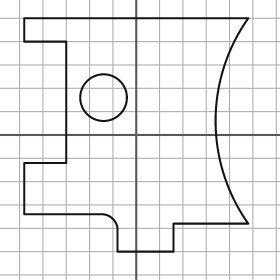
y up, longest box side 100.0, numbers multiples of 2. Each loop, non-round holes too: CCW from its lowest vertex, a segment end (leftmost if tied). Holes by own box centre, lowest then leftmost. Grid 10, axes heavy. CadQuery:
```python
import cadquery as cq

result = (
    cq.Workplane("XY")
    .moveTo(-8.0, -50.0)
    .lineTo(16.0, -50.0)
    .lineTo(16.0, -38.0)
    .lineTo(48.0, -38.0)
    .threePointArc((34.0, 6.0), (48.0, 50.0))
    .lineTo(-48.0, 50.0)
    .lineTo(-48.0, 40.0)
    .lineTo(-30.0, 40.0)
    .lineTo(-30.0, -12.0)
    .lineTo(-48.0, -12.0)
    .lineTo(-48.0, -34.0)
    .lineTo(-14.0, -34.0)
    .threePointArc((-10.0, -36.0), (-8.0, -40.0))
    .close()
    .moveTo(-14.0, 16.0)
    .circle(10.0)
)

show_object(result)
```